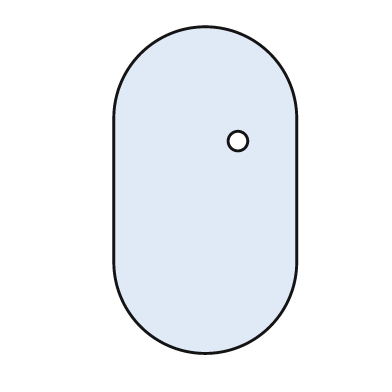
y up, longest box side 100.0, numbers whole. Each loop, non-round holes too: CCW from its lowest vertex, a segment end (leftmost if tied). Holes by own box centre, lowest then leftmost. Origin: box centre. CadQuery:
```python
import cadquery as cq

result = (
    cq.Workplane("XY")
    .moveTo(-28.0, -22.0)
    .threePointArc((0.0, -50.0), (28.0, -22.0))
    .lineTo(28.0, 22.0)
    .threePointArc((0.0, 50.0), (-28.0, 22.0))
    .close()
    .moveTo(10.0, 15.0)
    .circle(3.0)
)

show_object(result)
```